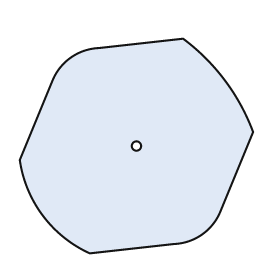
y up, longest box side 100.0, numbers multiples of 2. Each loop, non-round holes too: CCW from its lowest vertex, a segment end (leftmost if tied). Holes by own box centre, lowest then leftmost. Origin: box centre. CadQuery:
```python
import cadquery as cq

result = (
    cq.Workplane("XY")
    .moveTo(-20.0, -46.0)
    .lineTo(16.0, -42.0)
    .threePointArc((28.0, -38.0), (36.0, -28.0))
    .lineTo(50.0, 6.0)
    .threePointArc((38.0, 28.0), (20.0, 46.0))
    .lineTo(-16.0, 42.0)
    .threePointArc((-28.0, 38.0), (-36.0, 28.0))
    .lineTo(-50.0, -6.0)
    .threePointArc((-40.0, -30.0), (-20.0, -46.0))
    .close()
    .moveTo(0.0, 0.0)
    .circle(2.0)
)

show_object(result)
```